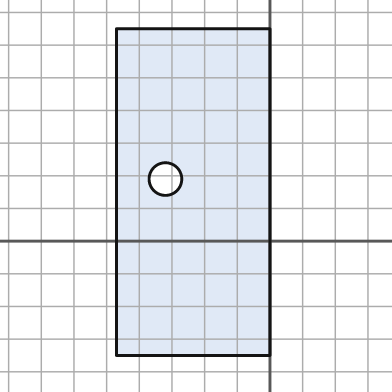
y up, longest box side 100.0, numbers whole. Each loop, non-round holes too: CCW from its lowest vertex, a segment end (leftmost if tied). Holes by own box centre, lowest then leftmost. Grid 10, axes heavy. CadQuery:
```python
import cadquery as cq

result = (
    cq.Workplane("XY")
    .moveTo(-47.0, -35.0)
    .lineTo(0.0, -35.0)
    .lineTo(0.0, 65.0)
    .lineTo(-47.0, 65.0)
    .close()
    .moveTo(-32.0, 19.0)
    .circle(5.0)
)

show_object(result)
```